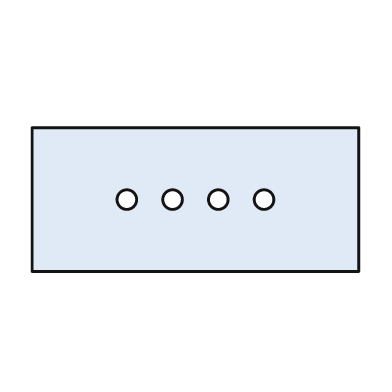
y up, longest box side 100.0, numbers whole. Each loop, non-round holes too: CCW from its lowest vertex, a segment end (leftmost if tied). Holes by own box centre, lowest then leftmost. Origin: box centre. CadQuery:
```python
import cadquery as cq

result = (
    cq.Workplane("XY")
    .moveTo(-50.0, -22.0)
    .lineTo(50.0, -22.0)
    .lineTo(50.0, 22.0)
    .lineTo(-50.0, 22.0)
    .close()
    .moveTo(-21.0, 0.0)
    .circle(3.0)
    .moveTo(-7.0, 0.0)
    .circle(3.0)
    .moveTo(7.0, 0.0)
    .circle(3.0)
    .moveTo(21.0, 0.0)
    .circle(3.0)
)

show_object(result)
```